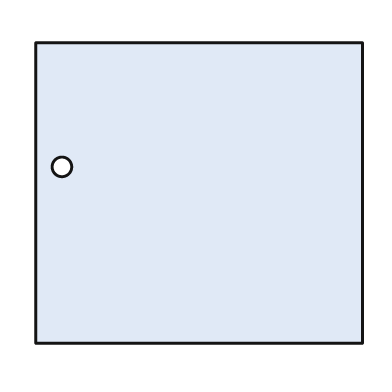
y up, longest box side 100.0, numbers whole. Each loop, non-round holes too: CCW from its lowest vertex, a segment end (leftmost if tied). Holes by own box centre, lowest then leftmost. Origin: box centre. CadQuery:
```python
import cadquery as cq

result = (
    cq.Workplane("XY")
    .moveTo(-50.0, -46.0)
    .lineTo(50.0, -46.0)
    .lineTo(50.0, 46.0)
    .lineTo(-50.0, 46.0)
    .close()
    .moveTo(-42.0, 8.0)
    .circle(3.0)
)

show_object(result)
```